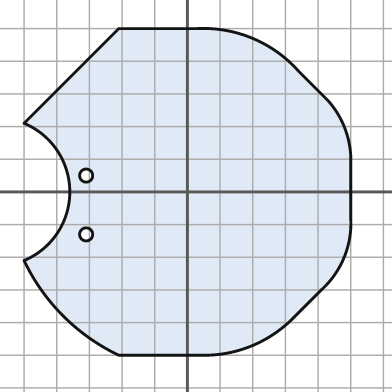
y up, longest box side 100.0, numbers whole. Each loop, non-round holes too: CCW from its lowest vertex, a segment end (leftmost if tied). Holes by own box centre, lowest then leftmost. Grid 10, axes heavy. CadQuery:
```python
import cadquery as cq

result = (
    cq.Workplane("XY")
    .moveTo(-21.0, -50.0)
    .lineTo(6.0, -50.0)
    .threePointArc((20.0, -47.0), (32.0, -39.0))
    .lineTo(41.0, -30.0)
    .threePointArc((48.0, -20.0), (50.0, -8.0))
    .lineTo(50.0, 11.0)
    .threePointArc((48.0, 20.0), (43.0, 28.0))
    .lineTo(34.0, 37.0)
    .threePointArc((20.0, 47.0), (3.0, 50.0))
    .lineTo(-21.0, 50.0)
    .lineTo(-50.0, 21.0)
    .threePointArc((-36.0, 0.0), (-50.0, -21.0))
    .threePointArc((-38.0, -38.0), (-21.0, -50.0))
    .close()
    .moveTo(-31.0, -13.0)
    .circle(2.0)
    .moveTo(-31.0, 5.0)
    .circle(2.0)
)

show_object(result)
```